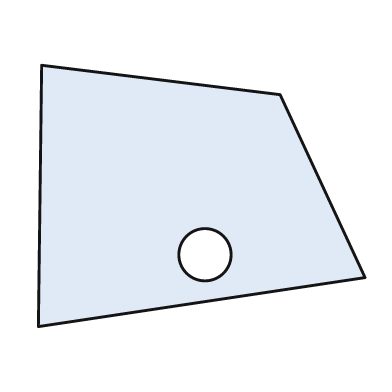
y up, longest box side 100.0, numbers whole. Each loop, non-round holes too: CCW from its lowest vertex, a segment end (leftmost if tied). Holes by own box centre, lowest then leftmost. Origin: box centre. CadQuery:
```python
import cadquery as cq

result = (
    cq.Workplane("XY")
    .moveTo(-50.0, -40.0)
    .lineTo(50.0, -25.0)
    .lineTo(24.0, 31.0)
    .lineTo(-49.0, 40.0)
    .close()
    .moveTo(1.0, -18.0)
    .circle(8.0)
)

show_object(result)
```